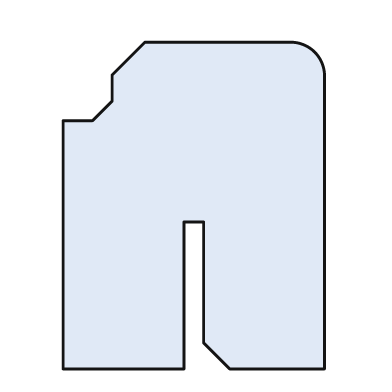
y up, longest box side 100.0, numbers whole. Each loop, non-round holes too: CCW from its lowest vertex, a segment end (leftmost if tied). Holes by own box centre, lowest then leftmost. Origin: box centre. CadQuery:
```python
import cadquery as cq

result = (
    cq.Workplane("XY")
    .moveTo(-40.0, -50.0)
    .lineTo(-3.0, -50.0)
    .lineTo(-3.0, -5.0)
    .lineTo(3.0, -5.0)
    .lineTo(3.0, -42.0)
    .lineTo(11.0, -50.0)
    .lineTo(40.0, -50.0)
    .lineTo(40.0, 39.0)
    .threePointArc((37.0, 47.0), (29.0, 50.0))
    .lineTo(-15.0, 50.0)
    .lineTo(-25.0, 40.0)
    .lineTo(-25.0, 32.0)
    .lineTo(-31.0, 26.0)
    .lineTo(-40.0, 26.0)
    .close()
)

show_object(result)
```